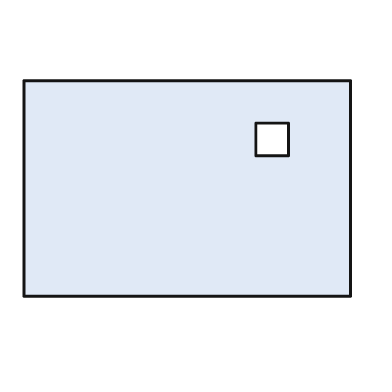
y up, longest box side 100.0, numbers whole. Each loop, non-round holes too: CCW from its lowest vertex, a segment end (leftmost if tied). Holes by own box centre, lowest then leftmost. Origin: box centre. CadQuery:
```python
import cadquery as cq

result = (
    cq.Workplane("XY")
    .moveTo(-50.0, -33.0)
    .lineTo(50.0, -33.0)
    .lineTo(50.0, 33.0)
    .lineTo(-50.0, 33.0)
    .close()
    .moveTo(21.0, 10.0)
    .lineTo(31.0, 10.0)
    .lineTo(31.0, 20.0)
    .lineTo(21.0, 20.0)
    .close()
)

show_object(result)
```